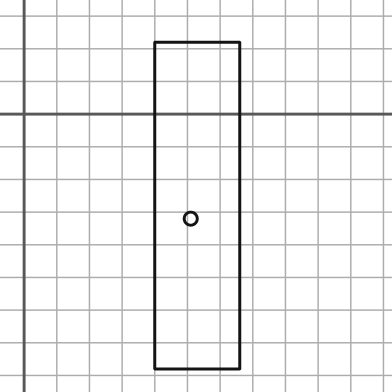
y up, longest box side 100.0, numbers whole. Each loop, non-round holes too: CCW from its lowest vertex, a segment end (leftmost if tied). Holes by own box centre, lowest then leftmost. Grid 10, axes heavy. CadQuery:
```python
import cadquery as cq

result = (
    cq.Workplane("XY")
    .moveTo(40.0, -78.0)
    .lineTo(66.0, -78.0)
    .lineTo(66.0, 22.0)
    .lineTo(40.0, 22.0)
    .close()
    .moveTo(51.0, -32.0)
    .circle(2.0)
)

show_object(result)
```